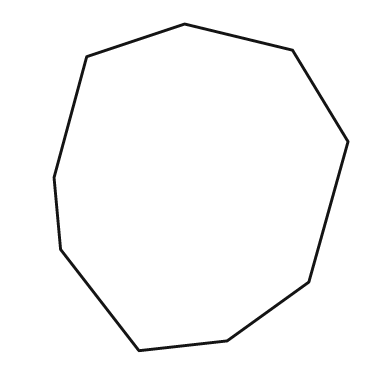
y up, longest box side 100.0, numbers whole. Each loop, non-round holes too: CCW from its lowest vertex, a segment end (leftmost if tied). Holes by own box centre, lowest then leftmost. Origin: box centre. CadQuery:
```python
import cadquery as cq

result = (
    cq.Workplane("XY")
    .moveTo(-19.0, -50.0)
    .lineTo(8.0, -47.0)
    .lineTo(33.0, -29.0)
    .lineTo(45.0, 14.0)
    .lineTo(28.0, 42.0)
    .lineTo(-5.0, 50.0)
    .lineTo(-35.0, 40.0)
    .lineTo(-45.0, 3.0)
    .lineTo(-43.0, -19.0)
    .close()
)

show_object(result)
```